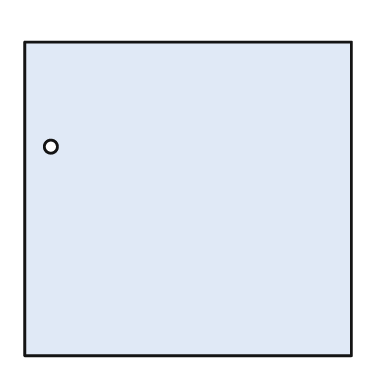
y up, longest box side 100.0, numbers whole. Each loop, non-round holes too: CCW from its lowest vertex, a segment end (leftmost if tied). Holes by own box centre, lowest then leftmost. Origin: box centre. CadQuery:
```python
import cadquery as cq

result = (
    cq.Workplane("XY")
    .moveTo(-50.0, -48.0)
    .lineTo(50.0, -48.0)
    .lineTo(50.0, 48.0)
    .lineTo(-50.0, 48.0)
    .close()
    .moveTo(-42.0, 16.0)
    .circle(2.0)
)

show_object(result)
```